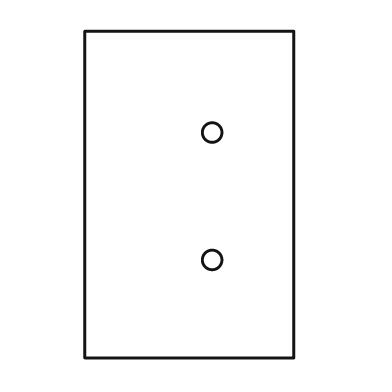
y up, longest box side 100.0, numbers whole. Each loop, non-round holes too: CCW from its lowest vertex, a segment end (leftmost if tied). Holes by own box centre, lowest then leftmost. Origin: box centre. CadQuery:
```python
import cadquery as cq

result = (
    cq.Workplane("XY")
    .moveTo(-32.0, -50.0)
    .lineTo(32.0, -50.0)
    .lineTo(32.0, 50.0)
    .lineTo(-32.0, 50.0)
    .close()
    .moveTo(7.0, -20.0)
    .circle(3.0)
    .moveTo(7.0, 19.0)
    .circle(3.0)
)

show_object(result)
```